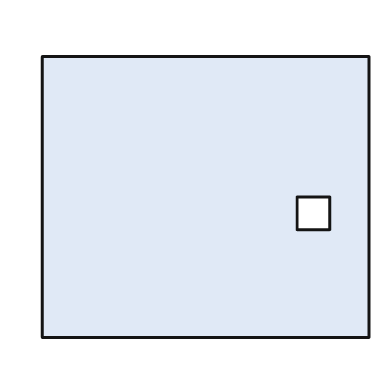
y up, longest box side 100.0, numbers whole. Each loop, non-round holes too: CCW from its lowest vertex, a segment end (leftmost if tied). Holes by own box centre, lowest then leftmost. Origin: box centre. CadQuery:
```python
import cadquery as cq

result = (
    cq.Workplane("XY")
    .moveTo(-50.0, -43.0)
    .lineTo(50.0, -43.0)
    .lineTo(50.0, 43.0)
    .lineTo(-50.0, 43.0)
    .close()
    .moveTo(28.0, -10.0)
    .lineTo(38.0, -10.0)
    .lineTo(38.0, 0.0)
    .lineTo(28.0, 0.0)
    .close()
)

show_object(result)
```